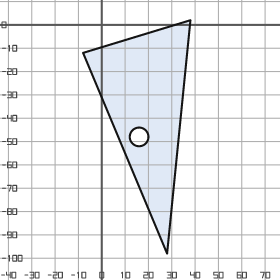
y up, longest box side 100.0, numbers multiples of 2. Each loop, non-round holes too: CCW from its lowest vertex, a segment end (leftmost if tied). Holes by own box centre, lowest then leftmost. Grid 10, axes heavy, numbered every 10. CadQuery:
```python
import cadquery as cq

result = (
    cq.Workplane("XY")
    .moveTo(28.0, -98.0)
    .lineTo(38.0, 2.0)
    .lineTo(-8.0, -12.0)
    .close()
    .moveTo(16.0, -48.0)
    .circle(4.0)
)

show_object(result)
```